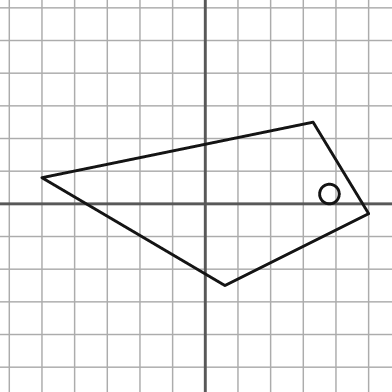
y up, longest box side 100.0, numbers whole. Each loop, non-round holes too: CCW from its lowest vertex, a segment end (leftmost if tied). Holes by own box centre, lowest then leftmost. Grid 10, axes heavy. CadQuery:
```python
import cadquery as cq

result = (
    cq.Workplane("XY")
    .moveTo(6.0, -25.0)
    .lineTo(50.0, -3.0)
    .lineTo(33.0, 25.0)
    .lineTo(-50.0, 8.0)
    .close()
    .moveTo(38.0, 3.0)
    .circle(3.0)
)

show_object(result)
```